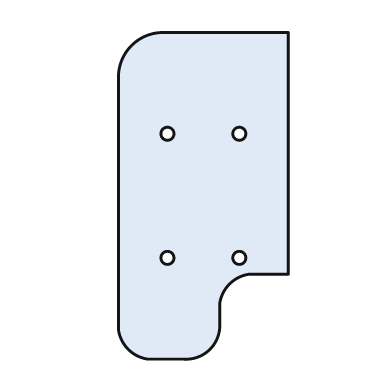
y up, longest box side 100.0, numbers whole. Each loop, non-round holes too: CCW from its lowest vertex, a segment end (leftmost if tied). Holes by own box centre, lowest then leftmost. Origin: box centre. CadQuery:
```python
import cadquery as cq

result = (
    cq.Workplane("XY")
    .moveTo(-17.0, -50.0)
    .lineTo(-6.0, -50.0)
    .threePointArc((2.0, -47.0), (5.0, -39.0))
    .lineTo(5.0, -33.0)
    .threePointArc((8.0, -27.0), (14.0, -24.0))
    .lineTo(26.0, -24.0)
    .lineTo(26.0, 50.0)
    .lineTo(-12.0, 50.0)
    .threePointArc((-22.0, 46.0), (-26.0, 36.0))
    .lineTo(-26.0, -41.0)
    .threePointArc((-23.0, -47.0), (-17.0, -50.0))
    .close()
    .moveTo(-11.0, -19.0)
    .circle(2.0)
    .moveTo(11.0, -19.0)
    .circle(2.0)
    .moveTo(-11.0, 19.0)
    .circle(2.0)
    .moveTo(11.0, 19.0)
    .circle(2.0)
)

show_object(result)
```